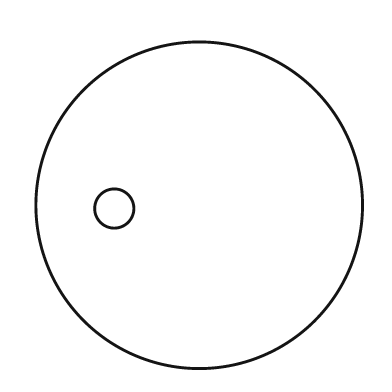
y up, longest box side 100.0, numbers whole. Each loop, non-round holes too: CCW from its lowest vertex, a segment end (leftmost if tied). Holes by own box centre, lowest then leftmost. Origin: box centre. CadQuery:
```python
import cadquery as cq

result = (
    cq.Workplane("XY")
    .moveTo(0.0, 0.0)
    .circle(50.0)
    .moveTo(-26.0, -1.0)
    .circle(6.0)
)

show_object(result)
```